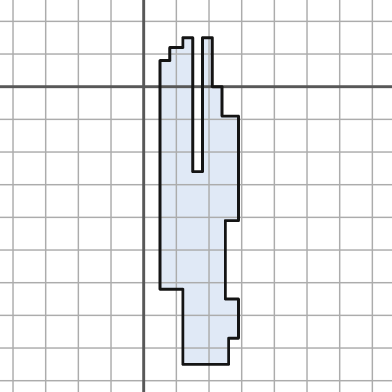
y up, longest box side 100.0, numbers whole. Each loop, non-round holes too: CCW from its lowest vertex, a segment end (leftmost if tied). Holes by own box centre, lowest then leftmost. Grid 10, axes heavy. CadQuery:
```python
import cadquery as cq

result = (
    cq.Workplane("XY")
    .moveTo(12.0, -85.0)
    .lineTo(26.0, -85.0)
    .lineTo(26.0, -77.0)
    .lineTo(29.0, -77.0)
    .lineTo(29.0, -65.0)
    .lineTo(25.0, -65.0)
    .lineTo(25.0, -41.0)
    .lineTo(29.0, -41.0)
    .lineTo(29.0, -9.0)
    .lineTo(24.0, -9.0)
    .lineTo(24.0, 0.0)
    .lineTo(21.0, 0.0)
    .lineTo(21.0, 15.0)
    .lineTo(18.0, 15.0)
    .lineTo(18.0, -26.0)
    .lineTo(15.0, -26.0)
    .lineTo(15.0, 15.0)
    .lineTo(12.0, 15.0)
    .lineTo(12.0, 12.0)
    .lineTo(8.0, 12.0)
    .lineTo(8.0, 8.0)
    .lineTo(5.0, 8.0)
    .lineTo(5.0, -62.0)
    .lineTo(12.0, -62.0)
    .close()
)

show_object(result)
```